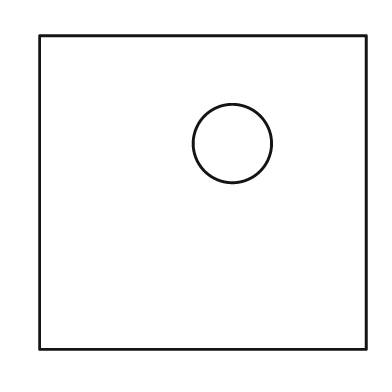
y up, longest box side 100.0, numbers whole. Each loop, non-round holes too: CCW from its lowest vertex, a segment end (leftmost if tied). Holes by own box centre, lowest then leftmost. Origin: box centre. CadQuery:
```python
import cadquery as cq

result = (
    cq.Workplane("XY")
    .moveTo(-50.0, -48.0)
    .lineTo(50.0, -48.0)
    .lineTo(50.0, 48.0)
    .lineTo(-50.0, 48.0)
    .close()
    .moveTo(9.0, 15.0)
    .circle(12.0)
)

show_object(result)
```